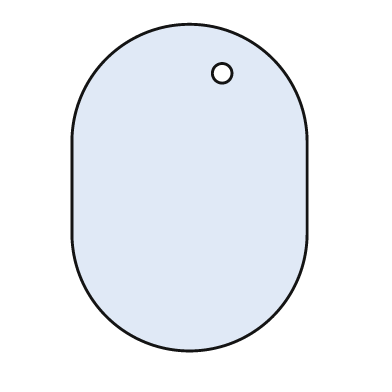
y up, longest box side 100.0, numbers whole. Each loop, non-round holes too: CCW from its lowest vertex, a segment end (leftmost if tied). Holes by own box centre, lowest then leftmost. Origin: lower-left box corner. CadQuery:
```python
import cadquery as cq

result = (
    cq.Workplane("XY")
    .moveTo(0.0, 36.0)
    .threePointArc((36.0, 0.0), (72.0, 36.0))
    .lineTo(72.0, 64.0)
    .threePointArc((36.0, 100.0), (0.0, 64.0))
    .close()
    .moveTo(46.0, 85.0)
    .circle(3.0)
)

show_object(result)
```